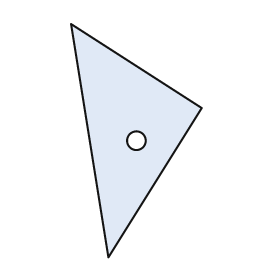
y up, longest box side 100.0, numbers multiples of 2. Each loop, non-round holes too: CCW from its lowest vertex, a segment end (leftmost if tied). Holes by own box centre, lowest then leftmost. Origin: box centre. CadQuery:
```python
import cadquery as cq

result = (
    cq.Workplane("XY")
    .moveTo(-12.0, -50.0)
    .lineTo(28.0, 14.0)
    .lineTo(-28.0, 50.0)
    .close()
    .moveTo(0.0, 0.0)
    .circle(4.0)
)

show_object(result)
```